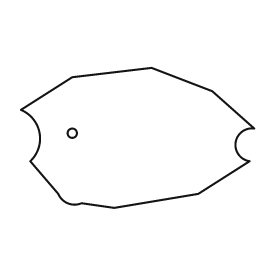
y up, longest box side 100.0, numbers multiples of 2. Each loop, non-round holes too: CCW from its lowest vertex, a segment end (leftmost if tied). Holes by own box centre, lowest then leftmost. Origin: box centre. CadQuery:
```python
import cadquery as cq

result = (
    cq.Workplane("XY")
    .moveTo(-10.0, -30.0)
    .lineTo(26.0, -24.0)
    .lineTo(48.0, -10.0)
    .threePointArc((42.0, -2.0), (50.0, 4.0))
    .lineTo(32.0, 20.0)
    .lineTo(6.0, 30.0)
    .lineTo(-28.0, 26.0)
    .lineTo(-50.0, 12.0)
    .threePointArc((-42.0, 2.0), (-46.0, -10.0))
    .lineTo(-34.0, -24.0)
    .threePointArc((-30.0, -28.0), (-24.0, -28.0))
    .close()
    .moveTo(-28.0, 2.0)
    .circle(2.0)
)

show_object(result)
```